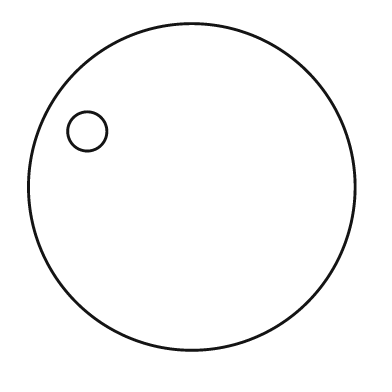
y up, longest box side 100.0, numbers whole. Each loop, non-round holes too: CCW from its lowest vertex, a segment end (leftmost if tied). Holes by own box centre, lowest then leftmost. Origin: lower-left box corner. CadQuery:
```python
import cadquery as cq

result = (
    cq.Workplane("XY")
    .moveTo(50.0, 50.0)
    .circle(50.0)
    .moveTo(18.0, 67.0)
    .circle(6.0)
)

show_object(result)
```